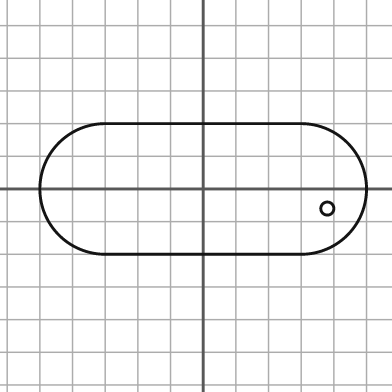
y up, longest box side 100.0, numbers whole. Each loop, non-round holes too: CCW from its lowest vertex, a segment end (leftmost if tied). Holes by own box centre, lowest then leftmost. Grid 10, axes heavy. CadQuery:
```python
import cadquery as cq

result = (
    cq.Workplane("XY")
    .moveTo(-30.0, -20.0)
    .lineTo(30.0, -20.0)
    .threePointArc((50.0, 0.0), (30.0, 20.0))
    .lineTo(-30.0, 20.0)
    .threePointArc((-50.0, 0.0), (-30.0, -20.0))
    .close()
    .moveTo(38.0, -6.0)
    .circle(2.0)
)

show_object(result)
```